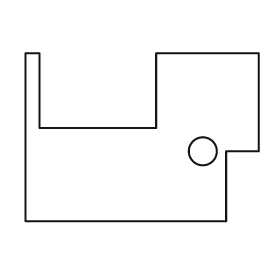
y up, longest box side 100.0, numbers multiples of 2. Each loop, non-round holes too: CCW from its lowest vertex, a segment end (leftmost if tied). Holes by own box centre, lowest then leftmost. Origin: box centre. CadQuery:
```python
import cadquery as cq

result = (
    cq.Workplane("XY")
    .moveTo(-50.0, -36.0)
    .lineTo(36.0, -36.0)
    .lineTo(36.0, -6.0)
    .lineTo(50.0, -6.0)
    .lineTo(50.0, 36.0)
    .lineTo(6.0, 36.0)
    .lineTo(6.0, 4.0)
    .lineTo(-44.0, 4.0)
    .lineTo(-44.0, 36.0)
    .lineTo(-50.0, 36.0)
    .close()
    .moveTo(26.0, -6.0)
    .circle(6.0)
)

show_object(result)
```